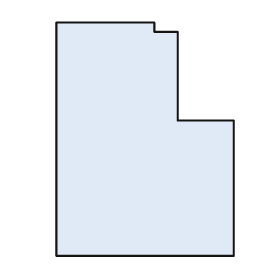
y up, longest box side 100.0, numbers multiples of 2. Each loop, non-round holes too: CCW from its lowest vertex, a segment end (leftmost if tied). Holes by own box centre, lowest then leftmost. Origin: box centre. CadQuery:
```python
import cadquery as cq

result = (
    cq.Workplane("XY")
    .moveTo(-38.0, -50.0)
    .lineTo(38.0, -50.0)
    .lineTo(38.0, 8.0)
    .lineTo(14.0, 8.0)
    .lineTo(14.0, 46.0)
    .lineTo(4.0, 46.0)
    .lineTo(4.0, 50.0)
    .lineTo(-38.0, 50.0)
    .close()
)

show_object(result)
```